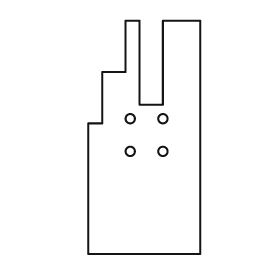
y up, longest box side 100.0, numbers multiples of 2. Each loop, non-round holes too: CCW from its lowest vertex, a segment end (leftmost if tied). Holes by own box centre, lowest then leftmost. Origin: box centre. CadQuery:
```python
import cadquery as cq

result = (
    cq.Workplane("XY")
    .moveTo(-24.0, -50.0)
    .lineTo(24.0, -50.0)
    .lineTo(24.0, 50.0)
    .lineTo(8.0, 50.0)
    .lineTo(8.0, 14.0)
    .lineTo(-2.0, 14.0)
    .lineTo(-2.0, 50.0)
    .lineTo(-8.0, 50.0)
    .lineTo(-8.0, 28.0)
    .lineTo(-18.0, 28.0)
    .lineTo(-18.0, 6.0)
    .lineTo(-24.0, 6.0)
    .close()
    .moveTo(-6.0, -6.0)
    .circle(2.0)
    .moveTo(8.0, -6.0)
    .circle(2.0)
    .moveTo(-6.0, 8.0)
    .circle(2.0)
    .moveTo(8.0, 8.0)
    .circle(2.0)
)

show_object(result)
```